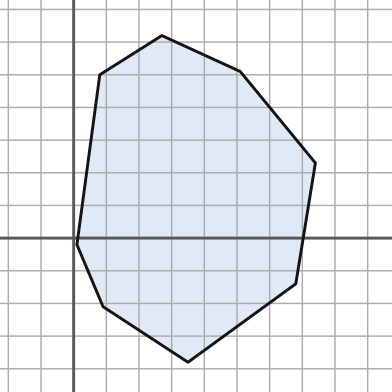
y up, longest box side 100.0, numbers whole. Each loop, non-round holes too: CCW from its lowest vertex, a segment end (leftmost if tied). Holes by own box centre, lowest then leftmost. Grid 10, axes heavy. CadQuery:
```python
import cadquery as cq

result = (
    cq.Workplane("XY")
    .moveTo(35.0, -38.0)
    .lineTo(68.0, -14.0)
    .lineTo(74.0, 23.0)
    .lineTo(51.0, 51.0)
    .lineTo(27.0, 62.0)
    .lineTo(8.0, 50.0)
    .lineTo(1.0, -2.0)
    .lineTo(9.0, -21.0)
    .close()
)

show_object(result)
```